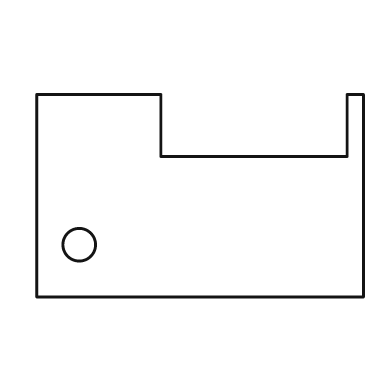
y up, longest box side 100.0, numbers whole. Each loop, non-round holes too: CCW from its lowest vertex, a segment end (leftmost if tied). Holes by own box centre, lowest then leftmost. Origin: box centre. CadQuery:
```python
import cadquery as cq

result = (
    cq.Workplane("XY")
    .moveTo(-50.0, -31.0)
    .lineTo(50.0, -31.0)
    .lineTo(50.0, 31.0)
    .lineTo(45.0, 31.0)
    .lineTo(45.0, 12.0)
    .lineTo(-12.0, 12.0)
    .lineTo(-12.0, 31.0)
    .lineTo(-50.0, 31.0)
    .close()
    .moveTo(-37.0, -15.0)
    .circle(5.0)
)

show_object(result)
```